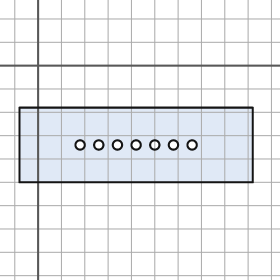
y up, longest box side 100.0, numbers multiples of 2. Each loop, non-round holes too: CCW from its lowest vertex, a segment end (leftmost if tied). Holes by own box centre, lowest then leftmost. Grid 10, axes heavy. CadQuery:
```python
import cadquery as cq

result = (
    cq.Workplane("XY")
    .moveTo(-8.0, -50.0)
    .lineTo(92.0, -50.0)
    .lineTo(92.0, -18.0)
    .lineTo(-8.0, -18.0)
    .close()
    .moveTo(18.0, -34.0)
    .circle(2.0)
    .moveTo(26.0, -34.0)
    .circle(2.0)
    .moveTo(34.0, -34.0)
    .circle(2.0)
    .moveTo(42.0, -34.0)
    .circle(2.0)
    .moveTo(50.0, -34.0)
    .circle(2.0)
    .moveTo(58.0, -34.0)
    .circle(2.0)
    .moveTo(66.0, -34.0)
    .circle(2.0)
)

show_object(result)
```